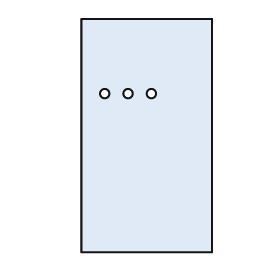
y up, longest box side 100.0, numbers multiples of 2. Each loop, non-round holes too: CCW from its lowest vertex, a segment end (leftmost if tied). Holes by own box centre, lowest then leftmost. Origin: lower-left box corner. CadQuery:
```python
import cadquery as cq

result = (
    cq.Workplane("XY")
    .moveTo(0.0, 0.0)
    .lineTo(56.0, 0.0)
    .lineTo(56.0, 100.0)
    .lineTo(0.0, 100.0)
    .close()
    .moveTo(10.0, 68.0)
    .circle(2.0)
    .moveTo(20.0, 68.0)
    .circle(2.0)
    .moveTo(30.0, 68.0)
    .circle(2.0)
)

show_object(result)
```